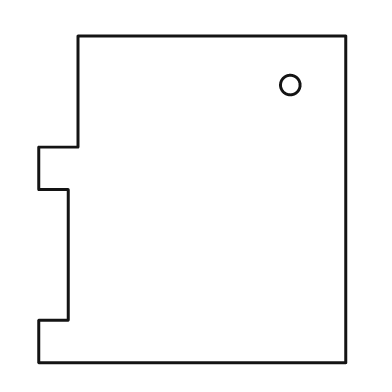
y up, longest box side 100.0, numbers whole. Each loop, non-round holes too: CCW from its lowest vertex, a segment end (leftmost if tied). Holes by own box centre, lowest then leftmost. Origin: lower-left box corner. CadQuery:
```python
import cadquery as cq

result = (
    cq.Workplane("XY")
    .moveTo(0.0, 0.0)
    .lineTo(94.0, 0.0)
    .lineTo(94.0, 100.0)
    .lineTo(12.0, 100.0)
    .lineTo(12.0, 66.0)
    .lineTo(0.0, 66.0)
    .lineTo(0.0, 53.0)
    .lineTo(9.0, 53.0)
    .lineTo(9.0, 13.0)
    .lineTo(0.0, 13.0)
    .close()
    .moveTo(77.0, 85.0)
    .circle(3.0)
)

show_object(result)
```